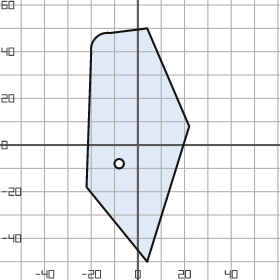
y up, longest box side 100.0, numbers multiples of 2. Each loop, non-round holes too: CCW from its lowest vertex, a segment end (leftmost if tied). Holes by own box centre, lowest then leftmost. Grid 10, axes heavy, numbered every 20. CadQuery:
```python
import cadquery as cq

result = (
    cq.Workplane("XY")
    .moveTo(4.0, -50.0)
    .lineTo(22.0, 8.0)
    .lineTo(4.0, 50.0)
    .lineTo(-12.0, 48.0)
    .threePointArc((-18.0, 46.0), (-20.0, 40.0))
    .lineTo(-22.0, -18.0)
    .close()
    .moveTo(-8.0, -8.0)
    .circle(2.0)
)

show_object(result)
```